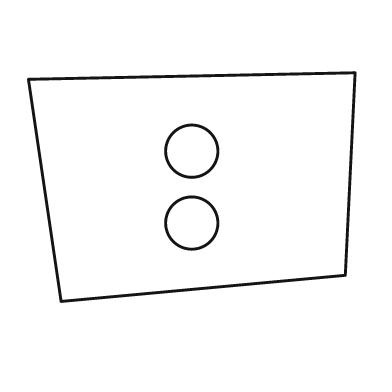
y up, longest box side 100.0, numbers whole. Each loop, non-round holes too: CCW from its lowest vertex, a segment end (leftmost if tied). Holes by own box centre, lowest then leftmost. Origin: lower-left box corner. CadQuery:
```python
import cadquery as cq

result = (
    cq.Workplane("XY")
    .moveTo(10.0, 0.0)
    .lineTo(97.0, 8.0)
    .lineTo(100.0, 70.0)
    .lineTo(0.0, 68.0)
    .close()
    .moveTo(50.0, 24.0)
    .circle(8.0)
    .moveTo(50.0, 46.0)
    .circle(8.0)
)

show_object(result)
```